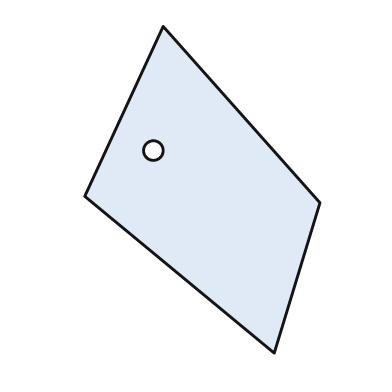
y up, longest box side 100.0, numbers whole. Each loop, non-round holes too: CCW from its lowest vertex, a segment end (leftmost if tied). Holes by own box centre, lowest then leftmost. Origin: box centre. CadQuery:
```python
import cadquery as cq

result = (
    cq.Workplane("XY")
    .moveTo(22.0, -50.0)
    .lineTo(36.0, -4.0)
    .lineTo(-12.0, 50.0)
    .lineTo(-36.0, -2.0)
    .close()
    .moveTo(-15.0, 12.0)
    .circle(3.0)
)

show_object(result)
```